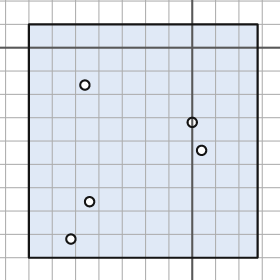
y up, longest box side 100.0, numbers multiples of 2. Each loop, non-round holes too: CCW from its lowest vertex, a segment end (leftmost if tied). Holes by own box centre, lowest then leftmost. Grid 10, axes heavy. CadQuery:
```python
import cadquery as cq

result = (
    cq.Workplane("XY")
    .moveTo(-70.0, -90.0)
    .lineTo(28.0, -90.0)
    .lineTo(28.0, 10.0)
    .lineTo(-70.0, 10.0)
    .close()
    .moveTo(-52.0, -82.0)
    .circle(2.0)
    .moveTo(-44.0, -66.0)
    .circle(2.0)
    .moveTo(4.0, -44.0)
    .circle(2.0)
    .moveTo(0.0, -32.0)
    .circle(2.0)
    .moveTo(-46.0, -16.0)
    .circle(2.0)
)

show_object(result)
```